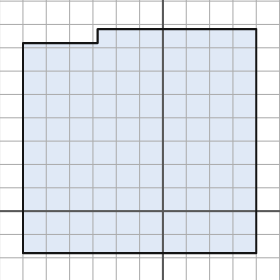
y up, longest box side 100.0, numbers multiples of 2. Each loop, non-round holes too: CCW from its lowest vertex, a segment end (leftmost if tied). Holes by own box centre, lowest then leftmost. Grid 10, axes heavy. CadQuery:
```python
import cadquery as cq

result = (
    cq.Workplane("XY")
    .moveTo(-60.0, -18.0)
    .lineTo(40.0, -18.0)
    .lineTo(40.0, 78.0)
    .lineTo(-28.0, 78.0)
    .lineTo(-28.0, 72.0)
    .lineTo(-60.0, 72.0)
    .close()
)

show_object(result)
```